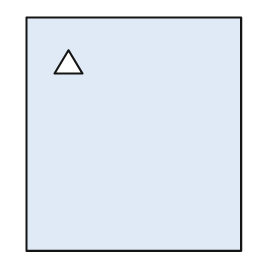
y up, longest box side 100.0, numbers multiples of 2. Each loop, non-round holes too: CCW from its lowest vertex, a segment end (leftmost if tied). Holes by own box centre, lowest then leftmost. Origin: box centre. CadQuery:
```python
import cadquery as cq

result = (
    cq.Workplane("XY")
    .moveTo(-46.0, -50.0)
    .lineTo(46.0, -50.0)
    .lineTo(46.0, 50.0)
    .lineTo(-46.0, 50.0)
    .close()
    .moveTo(-34.0, 26.0)
    .lineTo(-22.0, 26.0)
    .lineTo(-28.0, 36.0)
    .close()
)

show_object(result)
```